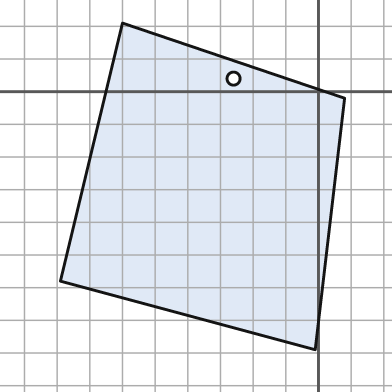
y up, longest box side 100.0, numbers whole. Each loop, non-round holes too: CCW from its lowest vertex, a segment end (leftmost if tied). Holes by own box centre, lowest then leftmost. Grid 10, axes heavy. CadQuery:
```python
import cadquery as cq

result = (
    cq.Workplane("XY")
    .moveTo(-1.0, -79.0)
    .lineTo(8.0, -2.0)
    .lineTo(-60.0, 21.0)
    .lineTo(-79.0, -58.0)
    .close()
    .moveTo(-26.0, 4.0)
    .circle(2.0)
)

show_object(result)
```